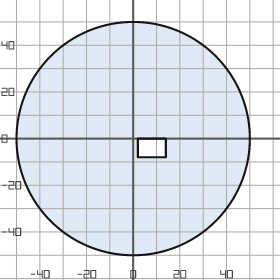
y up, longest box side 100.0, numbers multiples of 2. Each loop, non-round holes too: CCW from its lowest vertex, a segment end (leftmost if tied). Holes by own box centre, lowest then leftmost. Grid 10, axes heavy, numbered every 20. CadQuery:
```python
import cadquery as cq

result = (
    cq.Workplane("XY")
    .moveTo(0.0, 0.0)
    .circle(50.0)
    .moveTo(2.0, -8.0)
    .lineTo(14.0, -8.0)
    .lineTo(14.0, 0.0)
    .lineTo(2.0, 0.0)
    .close()
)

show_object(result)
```